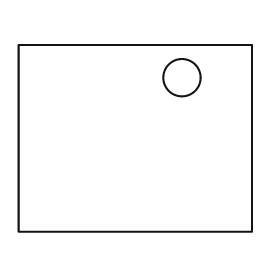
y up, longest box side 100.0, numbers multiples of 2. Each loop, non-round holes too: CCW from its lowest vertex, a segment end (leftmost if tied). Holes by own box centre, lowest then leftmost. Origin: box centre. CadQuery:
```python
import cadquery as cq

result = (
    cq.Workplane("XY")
    .moveTo(-50.0, -40.0)
    .lineTo(50.0, -40.0)
    .lineTo(50.0, 40.0)
    .lineTo(-50.0, 40.0)
    .close()
    .moveTo(20.0, 26.0)
    .circle(8.0)
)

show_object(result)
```